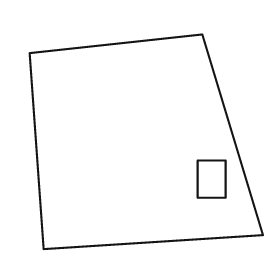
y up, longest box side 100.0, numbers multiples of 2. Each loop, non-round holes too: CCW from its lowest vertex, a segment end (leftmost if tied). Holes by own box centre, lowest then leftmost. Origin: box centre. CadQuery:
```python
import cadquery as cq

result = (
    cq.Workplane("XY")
    .moveTo(-44.0, -46.0)
    .lineTo(50.0, -40.0)
    .lineTo(24.0, 46.0)
    .lineTo(-50.0, 38.0)
    .close()
    .moveTo(22.0, -24.0)
    .lineTo(34.0, -24.0)
    .lineTo(34.0, -8.0)
    .lineTo(22.0, -8.0)
    .close()
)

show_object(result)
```